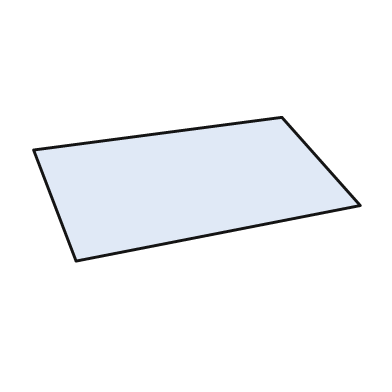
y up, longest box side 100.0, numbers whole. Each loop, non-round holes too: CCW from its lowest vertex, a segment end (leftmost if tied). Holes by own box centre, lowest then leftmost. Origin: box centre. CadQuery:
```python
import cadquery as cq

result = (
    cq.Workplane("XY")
    .moveTo(-37.0, -22.0)
    .lineTo(50.0, -5.0)
    .lineTo(26.0, 22.0)
    .lineTo(-50.0, 12.0)
    .close()
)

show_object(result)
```